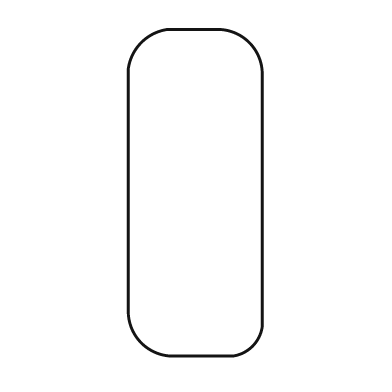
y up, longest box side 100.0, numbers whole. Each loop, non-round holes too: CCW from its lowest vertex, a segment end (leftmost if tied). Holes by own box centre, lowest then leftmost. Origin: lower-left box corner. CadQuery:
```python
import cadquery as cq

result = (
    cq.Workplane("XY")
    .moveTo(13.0, 0.0)
    .lineTo(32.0, 0.0)
    .threePointArc((38.0, 3.0), (41.0, 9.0))
    .lineTo(41.0, 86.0)
    .threePointArc((37.0, 96.0), (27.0, 100.0))
    .lineTo(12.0, 100.0)
    .threePointArc((4.0, 96.0), (0.0, 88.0))
    .lineTo(0.0, 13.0)
    .threePointArc((4.0, 4.0), (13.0, 0.0))
    .close()
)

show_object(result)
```